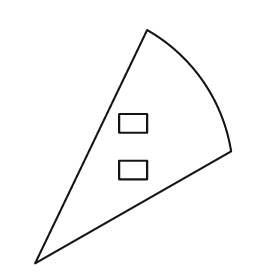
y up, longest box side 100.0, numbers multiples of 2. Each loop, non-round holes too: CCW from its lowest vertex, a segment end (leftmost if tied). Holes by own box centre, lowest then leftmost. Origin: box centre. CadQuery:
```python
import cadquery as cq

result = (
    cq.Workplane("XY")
    .moveTo(-42.0, -50.0)
    .lineTo(42.0, -2.0)
    .threePointArc((30.0, 28.0), (6.0, 50.0))
    .close()
    .moveTo(-6.0, -14.0)
    .lineTo(6.0, -14.0)
    .lineTo(6.0, -6.0)
    .lineTo(-6.0, -6.0)
    .close()
    .moveTo(-6.0, 6.0)
    .lineTo(6.0, 6.0)
    .lineTo(6.0, 14.0)
    .lineTo(-6.0, 14.0)
    .close()
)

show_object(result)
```